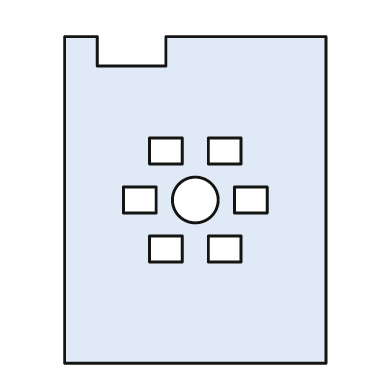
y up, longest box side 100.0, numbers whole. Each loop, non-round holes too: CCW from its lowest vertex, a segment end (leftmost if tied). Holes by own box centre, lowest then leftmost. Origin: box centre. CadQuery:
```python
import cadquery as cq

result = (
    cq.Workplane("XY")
    .moveTo(-40.0, -50.0)
    .lineTo(40.0, -50.0)
    .lineTo(40.0, 50.0)
    .lineTo(-9.0, 50.0)
    .lineTo(-9.0, 41.0)
    .lineTo(-30.0, 41.0)
    .lineTo(-30.0, 50.0)
    .lineTo(-40.0, 50.0)
    .close()
    .moveTo(-14.0, -19.0)
    .lineTo(-4.0, -19.0)
    .lineTo(-4.0, -11.0)
    .lineTo(-14.0, -11.0)
    .close()
    .moveTo(4.0, -19.0)
    .lineTo(14.0, -19.0)
    .lineTo(14.0, -11.0)
    .lineTo(4.0, -11.0)
    .close()
    .moveTo(-22.0, -4.0)
    .lineTo(-12.0, -4.0)
    .lineTo(-12.0, 4.0)
    .lineTo(-22.0, 4.0)
    .close()
    .moveTo(0.0, 0.0)
    .circle(7.0)
    .moveTo(12.0, -4.0)
    .lineTo(22.0, -4.0)
    .lineTo(22.0, 4.0)
    .lineTo(12.0, 4.0)
    .close()
    .moveTo(-14.0, 11.0)
    .lineTo(-4.0, 11.0)
    .lineTo(-4.0, 19.0)
    .lineTo(-14.0, 19.0)
    .close()
    .moveTo(4.0, 11.0)
    .lineTo(14.0, 11.0)
    .lineTo(14.0, 19.0)
    .lineTo(4.0, 19.0)
    .close()
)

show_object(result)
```